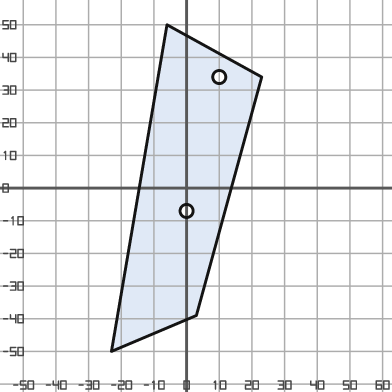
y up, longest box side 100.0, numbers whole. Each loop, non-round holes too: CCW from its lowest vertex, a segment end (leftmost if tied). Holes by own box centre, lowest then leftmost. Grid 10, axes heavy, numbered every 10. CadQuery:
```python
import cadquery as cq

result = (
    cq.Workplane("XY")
    .moveTo(-23.0, -50.0)
    .lineTo(3.0, -39.0)
    .lineTo(23.0, 34.0)
    .lineTo(-6.0, 50.0)
    .close()
    .moveTo(0.0, -7.0)
    .circle(2.0)
    .moveTo(10.0, 34.0)
    .circle(2.0)
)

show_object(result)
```